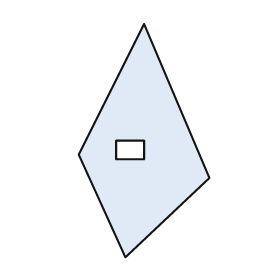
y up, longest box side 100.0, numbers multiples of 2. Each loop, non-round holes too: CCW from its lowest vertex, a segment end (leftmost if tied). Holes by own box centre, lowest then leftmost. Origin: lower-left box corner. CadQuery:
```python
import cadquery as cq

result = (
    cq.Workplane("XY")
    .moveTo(20.0, 0.0)
    .lineTo(56.0, 34.0)
    .lineTo(28.0, 100.0)
    .lineTo(0.0, 44.0)
    .close()
    .moveTo(16.0, 42.0)
    .lineTo(28.0, 42.0)
    .lineTo(28.0, 50.0)
    .lineTo(16.0, 50.0)
    .close()
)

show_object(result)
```